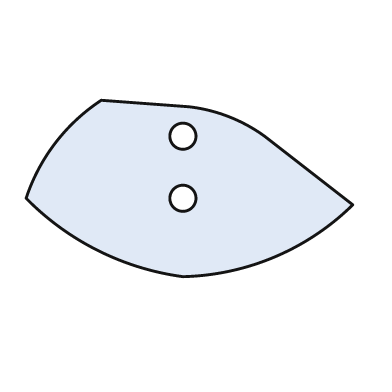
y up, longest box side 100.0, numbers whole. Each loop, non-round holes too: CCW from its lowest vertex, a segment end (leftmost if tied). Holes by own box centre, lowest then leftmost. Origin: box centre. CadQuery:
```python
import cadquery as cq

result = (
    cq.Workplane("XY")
    .moveTo(-2.0, -27.0)
    .threePointArc((26.0, -21.0), (50.0, -5.0))
    .lineTo(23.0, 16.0)
    .threePointArc((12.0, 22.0), (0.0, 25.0))
    .lineTo(-27.0, 27.0)
    .threePointArc((-41.0, 14.0), (-50.0, -3.0))
    .threePointArc((-28.0, -19.0), (-2.0, -27.0))
    .close()
    .moveTo(-2.0, -3.0)
    .circle(4.0)
    .moveTo(-2.0, 16.0)
    .circle(4.0)
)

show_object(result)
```